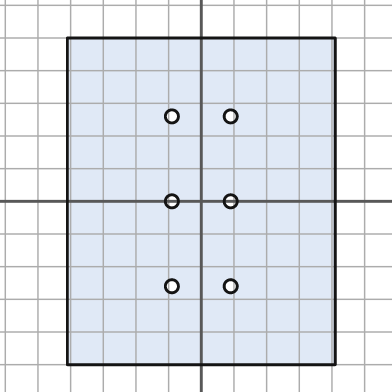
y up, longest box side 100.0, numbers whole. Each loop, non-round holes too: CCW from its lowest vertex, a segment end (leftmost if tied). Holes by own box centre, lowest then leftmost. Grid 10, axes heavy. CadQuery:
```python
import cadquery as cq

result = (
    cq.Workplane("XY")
    .moveTo(-41.0, -50.0)
    .lineTo(41.0, -50.0)
    .lineTo(41.0, 50.0)
    .lineTo(-41.0, 50.0)
    .close()
    .moveTo(-9.0, -26.0)
    .circle(2.0)
    .moveTo(9.0, -26.0)
    .circle(2.0)
    .moveTo(-9.0, 0.0)
    .circle(2.0)
    .moveTo(9.0, 0.0)
    .circle(2.0)
    .moveTo(-9.0, 26.0)
    .circle(2.0)
    .moveTo(9.0, 26.0)
    .circle(2.0)
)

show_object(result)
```